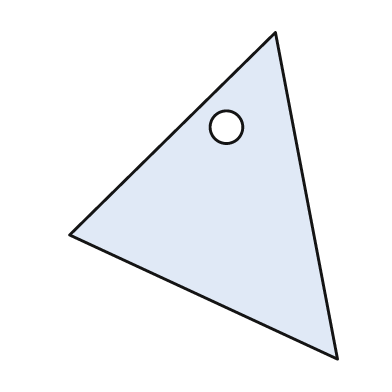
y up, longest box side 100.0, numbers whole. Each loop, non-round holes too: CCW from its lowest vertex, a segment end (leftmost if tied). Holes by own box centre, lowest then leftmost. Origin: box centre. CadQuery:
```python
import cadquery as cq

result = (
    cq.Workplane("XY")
    .moveTo(41.0, -50.0)
    .lineTo(22.0, 50.0)
    .lineTo(-41.0, -12.0)
    .close()
    .moveTo(7.0, 21.0)
    .circle(5.0)
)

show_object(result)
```